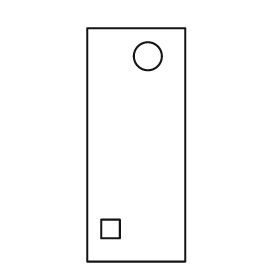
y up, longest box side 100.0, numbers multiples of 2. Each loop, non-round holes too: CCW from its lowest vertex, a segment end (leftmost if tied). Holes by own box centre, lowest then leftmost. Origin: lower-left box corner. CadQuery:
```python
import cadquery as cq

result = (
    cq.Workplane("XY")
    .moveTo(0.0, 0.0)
    .lineTo(42.0, 0.0)
    .lineTo(42.0, 100.0)
    .lineTo(0.0, 100.0)
    .close()
    .moveTo(6.0, 10.0)
    .lineTo(14.0, 10.0)
    .lineTo(14.0, 18.0)
    .lineTo(6.0, 18.0)
    .close()
    .moveTo(26.0, 88.0)
    .circle(6.0)
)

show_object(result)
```